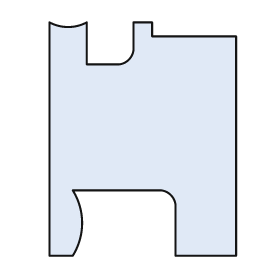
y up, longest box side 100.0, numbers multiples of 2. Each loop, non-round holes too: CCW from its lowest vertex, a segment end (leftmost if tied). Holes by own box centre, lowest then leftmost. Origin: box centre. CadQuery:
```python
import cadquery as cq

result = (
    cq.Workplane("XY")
    .moveTo(-40.0, -50.0)
    .lineTo(-30.0, -50.0)
    .threePointArc((-26.0, -36.0), (-30.0, -22.0))
    .lineTo(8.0, -22.0)
    .threePointArc((12.0, -24.0), (14.0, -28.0))
    .lineTo(14.0, -50.0)
    .lineTo(40.0, -50.0)
    .lineTo(40.0, 44.0)
    .lineTo(4.0, 44.0)
    .lineTo(4.0, 50.0)
    .lineTo(-4.0, 50.0)
    .lineTo(-4.0, 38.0)
    .threePointArc((-6.0, 34.0), (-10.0, 32.0))
    .lineTo(-24.0, 32.0)
    .lineTo(-24.0, 50.0)
    .threePointArc((-32.0, 48.0), (-40.0, 50.0))
    .close()
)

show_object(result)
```